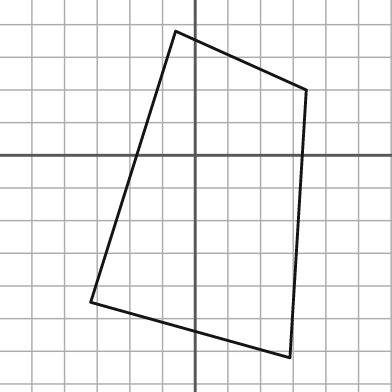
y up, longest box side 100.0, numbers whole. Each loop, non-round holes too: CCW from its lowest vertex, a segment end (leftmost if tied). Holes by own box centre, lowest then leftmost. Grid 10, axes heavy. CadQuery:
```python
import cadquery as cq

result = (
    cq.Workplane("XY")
    .moveTo(29.0, -62.0)
    .lineTo(34.0, 20.0)
    .lineTo(-6.0, 38.0)
    .lineTo(-32.0, -45.0)
    .close()
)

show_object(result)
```